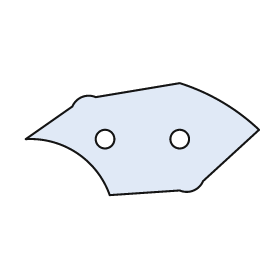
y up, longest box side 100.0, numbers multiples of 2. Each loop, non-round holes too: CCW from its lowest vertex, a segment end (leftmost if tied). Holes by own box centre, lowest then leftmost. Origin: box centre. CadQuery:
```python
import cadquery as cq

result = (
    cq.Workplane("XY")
    .moveTo(-14.0, -24.0)
    .lineTo(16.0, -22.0)
    .threePointArc((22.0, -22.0), (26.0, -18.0))
    .lineTo(50.0, 4.0)
    .threePointArc((34.0, 16.0), (16.0, 24.0))
    .lineTo(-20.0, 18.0)
    .threePointArc((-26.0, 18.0), (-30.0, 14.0))
    .lineTo(-50.0, 0.0)
    .threePointArc((-28.0, -6.0), (-14.0, -24.0))
    .close()
    .moveTo(-16.0, 0.0)
    .circle(4.0)
    .moveTo(16.0, 0.0)
    .circle(4.0)
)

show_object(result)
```